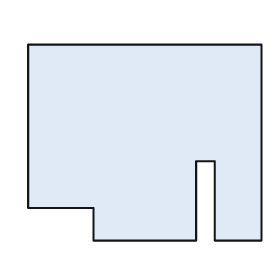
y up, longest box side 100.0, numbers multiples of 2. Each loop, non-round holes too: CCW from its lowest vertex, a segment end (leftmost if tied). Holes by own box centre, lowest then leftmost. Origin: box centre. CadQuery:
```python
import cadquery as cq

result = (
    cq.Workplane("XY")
    .moveTo(-22.0, -42.0)
    .lineTo(22.0, -42.0)
    .lineTo(22.0, -8.0)
    .lineTo(30.0, -8.0)
    .lineTo(30.0, -42.0)
    .lineTo(50.0, -42.0)
    .lineTo(50.0, 42.0)
    .lineTo(-50.0, 42.0)
    .lineTo(-50.0, -28.0)
    .lineTo(-22.0, -28.0)
    .close()
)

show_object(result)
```